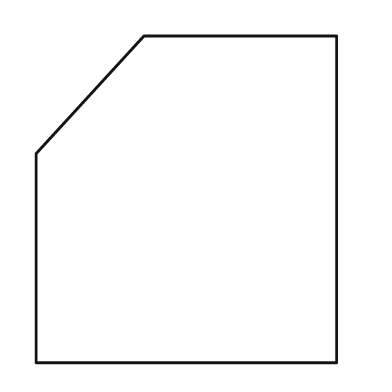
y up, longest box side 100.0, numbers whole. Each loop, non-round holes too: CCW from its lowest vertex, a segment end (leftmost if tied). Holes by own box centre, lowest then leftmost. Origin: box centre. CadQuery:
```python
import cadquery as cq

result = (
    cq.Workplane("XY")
    .moveTo(-46.0, -50.0)
    .lineTo(46.0, -50.0)
    .lineTo(46.0, 50.0)
    .lineTo(-13.0, 50.0)
    .lineTo(-46.0, 14.0)
    .close()
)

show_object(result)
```